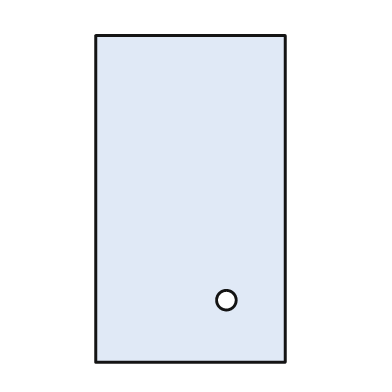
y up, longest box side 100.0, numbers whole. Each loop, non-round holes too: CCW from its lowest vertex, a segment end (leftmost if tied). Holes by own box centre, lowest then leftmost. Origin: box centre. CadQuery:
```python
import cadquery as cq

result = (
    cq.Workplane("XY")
    .moveTo(-29.0, -50.0)
    .lineTo(29.0, -50.0)
    .lineTo(29.0, 50.0)
    .lineTo(-29.0, 50.0)
    .close()
    .moveTo(11.0, -31.0)
    .circle(3.0)
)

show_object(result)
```